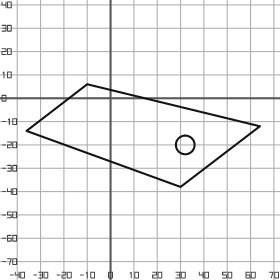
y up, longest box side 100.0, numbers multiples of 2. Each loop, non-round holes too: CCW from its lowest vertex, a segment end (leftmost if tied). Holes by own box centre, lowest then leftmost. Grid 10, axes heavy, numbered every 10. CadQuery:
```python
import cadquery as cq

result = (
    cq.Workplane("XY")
    .moveTo(30.0, -38.0)
    .lineTo(64.0, -12.0)
    .lineTo(-10.0, 6.0)
    .lineTo(-36.0, -14.0)
    .close()
    .moveTo(32.0, -20.0)
    .circle(4.0)
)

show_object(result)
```